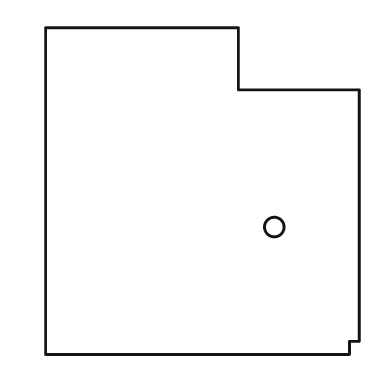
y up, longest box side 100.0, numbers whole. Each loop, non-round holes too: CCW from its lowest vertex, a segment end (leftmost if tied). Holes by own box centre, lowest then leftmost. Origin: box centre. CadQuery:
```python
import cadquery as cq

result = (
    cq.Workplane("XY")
    .moveTo(-48.0, -50.0)
    .lineTo(45.0, -50.0)
    .lineTo(45.0, -46.0)
    .lineTo(48.0, -46.0)
    .lineTo(48.0, 31.0)
    .lineTo(11.0, 31.0)
    .lineTo(11.0, 50.0)
    .lineTo(-48.0, 50.0)
    .close()
    .moveTo(22.0, -11.0)
    .circle(3.0)
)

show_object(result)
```